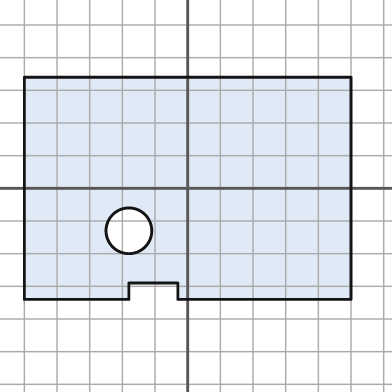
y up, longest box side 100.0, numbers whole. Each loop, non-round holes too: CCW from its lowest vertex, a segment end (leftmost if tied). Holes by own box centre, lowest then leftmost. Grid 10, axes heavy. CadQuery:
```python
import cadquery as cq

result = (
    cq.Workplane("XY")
    .moveTo(-50.0, -34.0)
    .lineTo(-18.0, -34.0)
    .lineTo(-18.0, -29.0)
    .lineTo(-3.0, -29.0)
    .lineTo(-3.0, -34.0)
    .lineTo(50.0, -34.0)
    .lineTo(50.0, 34.0)
    .lineTo(-50.0, 34.0)
    .close()
    .moveTo(-18.0, -13.0)
    .circle(7.0)
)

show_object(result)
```